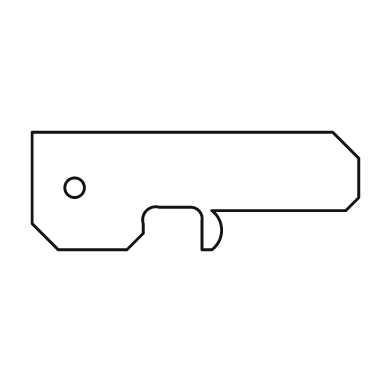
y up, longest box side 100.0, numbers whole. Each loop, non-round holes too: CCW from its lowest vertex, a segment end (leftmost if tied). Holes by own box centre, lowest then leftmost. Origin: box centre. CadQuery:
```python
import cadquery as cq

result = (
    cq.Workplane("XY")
    .moveTo(-42.0, -18.0)
    .lineTo(-21.0, -18.0)
    .lineTo(-16.0, -13.0)
    .lineTo(-16.0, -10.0)
    .threePointArc((-15.0, -6.0), (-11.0, -5.0))
    .lineTo(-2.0, -5.0)
    .threePointArc((1.0, -6.0), (2.0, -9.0))
    .lineTo(2.0, -18.0)
    .lineTo(5.0, -18.0)
    .threePointArc((8.0, -12.0), (5.0, -6.0))
    .lineTo(46.0, -6.0)
    .lineTo(50.0, -2.0)
    .lineTo(50.0, 10.0)
    .lineTo(42.0, 18.0)
    .lineTo(-50.0, 18.0)
    .lineTo(-50.0, -10.0)
    .close()
    .moveTo(-37.0, 1.0)
    .circle(3.0)
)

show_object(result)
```